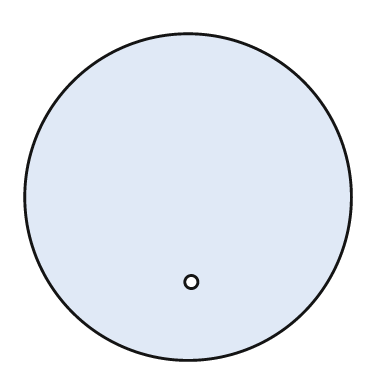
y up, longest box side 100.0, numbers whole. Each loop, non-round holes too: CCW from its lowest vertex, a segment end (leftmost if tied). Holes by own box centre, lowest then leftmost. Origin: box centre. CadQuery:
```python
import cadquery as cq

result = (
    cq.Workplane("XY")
    .moveTo(0.0, 0.0)
    .circle(50.0)
    .moveTo(1.0, -26.0)
    .circle(2.0)
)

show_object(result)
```